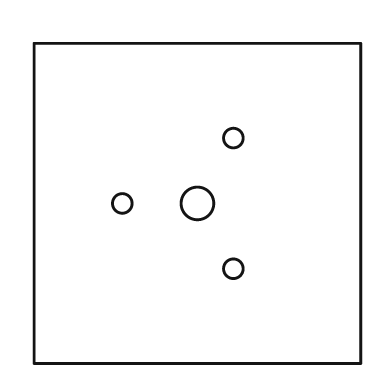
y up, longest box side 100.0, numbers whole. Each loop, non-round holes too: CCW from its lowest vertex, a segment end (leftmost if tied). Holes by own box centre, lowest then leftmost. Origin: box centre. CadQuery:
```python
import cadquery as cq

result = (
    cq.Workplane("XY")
    .moveTo(-50.0, -49.0)
    .lineTo(50.0, -49.0)
    .lineTo(50.0, 49.0)
    .lineTo(-50.0, 49.0)
    .close()
    .moveTo(11.0, -20.0)
    .circle(3.0)
    .moveTo(-23.0, 0.0)
    .circle(3.0)
    .moveTo(0.0, 0.0)
    .circle(5.0)
    .moveTo(11.0, 20.0)
    .circle(3.0)
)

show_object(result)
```